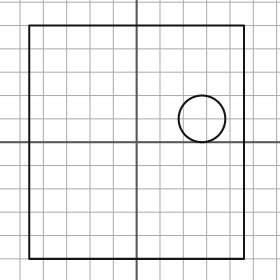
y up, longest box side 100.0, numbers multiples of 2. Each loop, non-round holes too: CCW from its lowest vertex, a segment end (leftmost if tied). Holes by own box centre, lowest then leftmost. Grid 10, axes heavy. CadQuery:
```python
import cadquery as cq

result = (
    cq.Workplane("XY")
    .moveTo(-46.0, -50.0)
    .lineTo(46.0, -50.0)
    .lineTo(46.0, 50.0)
    .lineTo(-46.0, 50.0)
    .close()
    .moveTo(28.0, 10.0)
    .circle(10.0)
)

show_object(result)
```